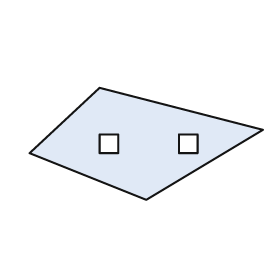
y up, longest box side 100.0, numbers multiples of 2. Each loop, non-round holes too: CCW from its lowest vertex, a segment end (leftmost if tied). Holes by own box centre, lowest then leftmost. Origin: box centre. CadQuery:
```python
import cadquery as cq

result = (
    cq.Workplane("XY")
    .moveTo(0.0, -24.0)
    .lineTo(50.0, 6.0)
    .lineTo(-20.0, 24.0)
    .lineTo(-50.0, -4.0)
    .close()
    .moveTo(-20.0, -4.0)
    .lineTo(-12.0, -4.0)
    .lineTo(-12.0, 4.0)
    .lineTo(-20.0, 4.0)
    .close()
    .moveTo(14.0, -4.0)
    .lineTo(22.0, -4.0)
    .lineTo(22.0, 4.0)
    .lineTo(14.0, 4.0)
    .close()
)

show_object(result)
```